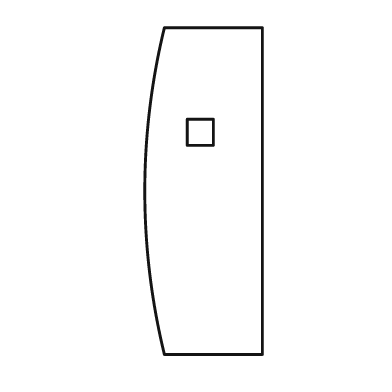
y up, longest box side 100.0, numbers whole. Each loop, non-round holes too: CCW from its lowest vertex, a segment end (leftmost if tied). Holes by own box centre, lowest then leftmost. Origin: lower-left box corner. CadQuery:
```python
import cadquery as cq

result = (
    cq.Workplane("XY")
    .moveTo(6.0, 0.0)
    .lineTo(36.0, 0.0)
    .lineTo(36.0, 100.0)
    .lineTo(6.0, 100.0)
    .threePointArc((0.0, 50.0), (6.0, 0.0))
    .close()
    .moveTo(13.0, 64.0)
    .lineTo(21.0, 64.0)
    .lineTo(21.0, 72.0)
    .lineTo(13.0, 72.0)
    .close()
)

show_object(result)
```